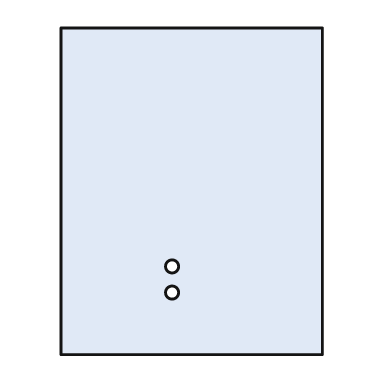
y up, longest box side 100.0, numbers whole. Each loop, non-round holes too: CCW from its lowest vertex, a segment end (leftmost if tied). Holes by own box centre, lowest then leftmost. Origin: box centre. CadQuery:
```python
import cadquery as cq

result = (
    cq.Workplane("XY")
    .moveTo(-40.0, -50.0)
    .lineTo(40.0, -50.0)
    .lineTo(40.0, 50.0)
    .lineTo(-40.0, 50.0)
    .close()
    .moveTo(-6.0, -31.0)
    .circle(2.0)
    .moveTo(-6.0, -23.0)
    .circle(2.0)
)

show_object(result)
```